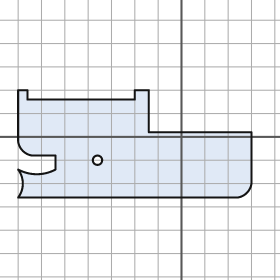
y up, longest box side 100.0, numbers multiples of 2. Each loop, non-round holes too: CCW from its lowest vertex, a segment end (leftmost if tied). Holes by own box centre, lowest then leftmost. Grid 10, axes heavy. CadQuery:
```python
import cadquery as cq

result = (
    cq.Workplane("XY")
    .moveTo(-70.0, -26.0)
    .lineTo(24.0, -26.0)
    .threePointArc((28.0, -24.0), (30.0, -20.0))
    .lineTo(30.0, 2.0)
    .lineTo(-14.0, 2.0)
    .lineTo(-14.0, 20.0)
    .lineTo(-20.0, 20.0)
    .lineTo(-20.0, 16.0)
    .lineTo(-66.0, 16.0)
    .lineTo(-66.0, 20.0)
    .lineTo(-70.0, 20.0)
    .lineTo(-70.0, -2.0)
    .threePointArc((-68.0, -6.0), (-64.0, -8.0))
    .lineTo(-54.0, -8.0)
    .lineTo(-54.0, -14.0)
    .threePointArc((-62.0, -16.0), (-70.0, -14.0))
    .threePointArc((-68.0, -20.0), (-70.0, -26.0))
    .close()
    .moveTo(-36.0, -10.0)
    .circle(2.0)
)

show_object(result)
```